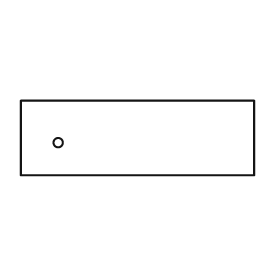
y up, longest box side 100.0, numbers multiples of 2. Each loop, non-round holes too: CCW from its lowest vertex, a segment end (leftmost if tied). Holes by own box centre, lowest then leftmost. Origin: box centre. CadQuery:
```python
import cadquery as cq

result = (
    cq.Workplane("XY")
    .moveTo(-50.0, -16.0)
    .lineTo(50.0, -16.0)
    .lineTo(50.0, 16.0)
    .lineTo(-50.0, 16.0)
    .close()
    .moveTo(-34.0, -2.0)
    .circle(2.0)
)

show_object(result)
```